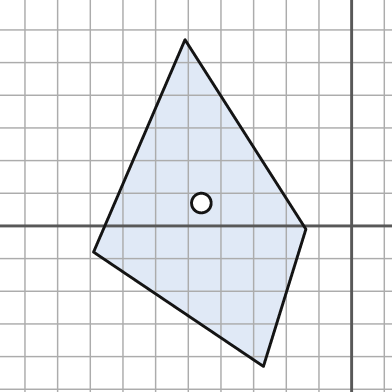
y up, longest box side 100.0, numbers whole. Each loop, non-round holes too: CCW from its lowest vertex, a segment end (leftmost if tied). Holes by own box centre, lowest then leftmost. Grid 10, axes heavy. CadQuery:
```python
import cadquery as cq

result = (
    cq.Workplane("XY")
    .moveTo(-27.0, -43.0)
    .lineTo(-14.0, -1.0)
    .lineTo(-51.0, 57.0)
    .lineTo(-79.0, -8.0)
    .close()
    .moveTo(-46.0, 7.0)
    .circle(3.0)
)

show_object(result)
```